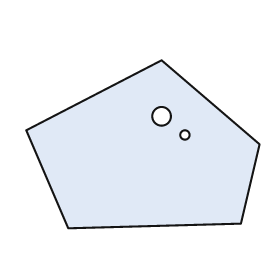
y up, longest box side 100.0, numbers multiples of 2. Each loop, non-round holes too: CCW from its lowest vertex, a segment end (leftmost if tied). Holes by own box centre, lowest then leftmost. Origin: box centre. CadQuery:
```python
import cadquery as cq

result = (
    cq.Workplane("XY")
    .moveTo(-32.0, -36.0)
    .lineTo(42.0, -34.0)
    .lineTo(50.0, 0.0)
    .lineTo(8.0, 36.0)
    .lineTo(-50.0, 6.0)
    .close()
    .moveTo(18.0, 4.0)
    .circle(2.0)
    .moveTo(8.0, 12.0)
    .circle(4.0)
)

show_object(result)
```